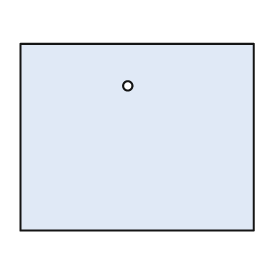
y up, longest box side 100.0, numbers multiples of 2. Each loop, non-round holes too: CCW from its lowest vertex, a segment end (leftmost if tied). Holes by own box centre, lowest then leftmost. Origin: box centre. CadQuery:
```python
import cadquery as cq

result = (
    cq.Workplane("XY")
    .moveTo(-50.0, -40.0)
    .lineTo(50.0, -40.0)
    .lineTo(50.0, 40.0)
    .lineTo(-50.0, 40.0)
    .close()
    .moveTo(-4.0, 22.0)
    .circle(2.0)
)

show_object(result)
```